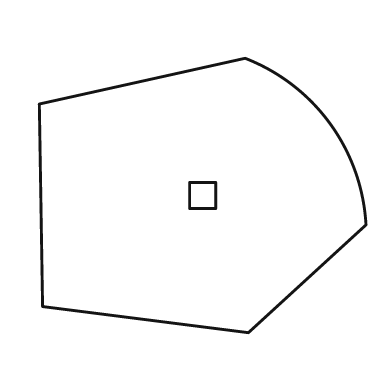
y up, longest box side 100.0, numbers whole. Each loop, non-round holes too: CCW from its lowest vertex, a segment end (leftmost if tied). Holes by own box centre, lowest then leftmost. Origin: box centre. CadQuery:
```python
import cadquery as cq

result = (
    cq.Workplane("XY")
    .moveTo(14.0, -42.0)
    .lineTo(50.0, -9.0)
    .threePointArc((39.0, 22.0), (13.0, 42.0))
    .lineTo(-50.0, 28.0)
    .lineTo(-49.0, -34.0)
    .close()
    .moveTo(-4.0, -4.0)
    .lineTo(4.0, -4.0)
    .lineTo(4.0, 4.0)
    .lineTo(-4.0, 4.0)
    .close()
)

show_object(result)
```